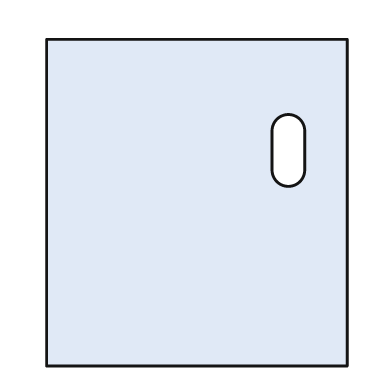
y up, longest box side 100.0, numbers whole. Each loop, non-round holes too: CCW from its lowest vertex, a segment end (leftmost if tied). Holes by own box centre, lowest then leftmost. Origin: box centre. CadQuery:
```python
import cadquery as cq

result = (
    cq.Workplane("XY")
    .moveTo(-46.0, -50.0)
    .lineTo(46.0, -50.0)
    .lineTo(46.0, 50.0)
    .lineTo(-46.0, 50.0)
    .close()
    .moveTo(23.0, 10.0)
    .threePointArc((28.0, 5.0), (33.0, 10.0))
    .lineTo(33.0, 22.0)
    .threePointArc((28.0, 27.0), (23.0, 22.0))
    .close()
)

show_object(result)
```